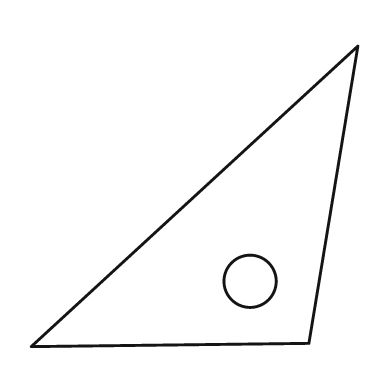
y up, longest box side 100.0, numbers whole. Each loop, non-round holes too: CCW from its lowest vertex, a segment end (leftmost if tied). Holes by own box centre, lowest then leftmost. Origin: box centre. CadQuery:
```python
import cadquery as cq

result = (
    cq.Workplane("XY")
    .moveTo(-50.0, -46.0)
    .lineTo(35.0, -45.0)
    .lineTo(50.0, 46.0)
    .close()
    .moveTo(17.0, -26.0)
    .circle(8.0)
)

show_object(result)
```